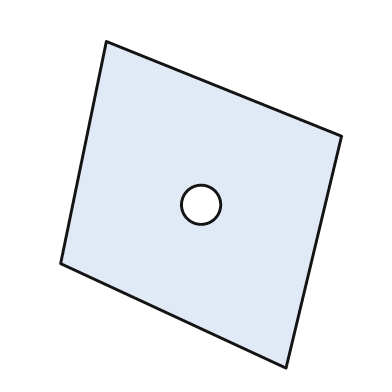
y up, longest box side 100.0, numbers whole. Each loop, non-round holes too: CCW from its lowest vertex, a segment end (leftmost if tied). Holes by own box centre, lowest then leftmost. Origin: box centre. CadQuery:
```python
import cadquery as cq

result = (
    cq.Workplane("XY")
    .moveTo(26.0, -50.0)
    .lineTo(43.0, 21.0)
    .lineTo(-29.0, 50.0)
    .lineTo(-43.0, -18.0)
    .close()
    .moveTo(0.0, 0.0)
    .circle(6.0)
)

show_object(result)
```